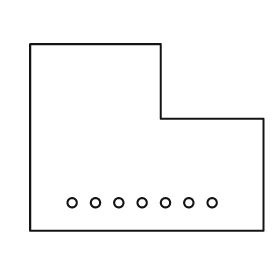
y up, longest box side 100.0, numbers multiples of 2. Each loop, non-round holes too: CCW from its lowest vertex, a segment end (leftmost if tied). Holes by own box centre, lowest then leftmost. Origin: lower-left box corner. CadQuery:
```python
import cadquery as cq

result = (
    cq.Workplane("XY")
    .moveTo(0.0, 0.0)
    .lineTo(100.0, 0.0)
    .lineTo(100.0, 48.0)
    .lineTo(56.0, 48.0)
    .lineTo(56.0, 80.0)
    .lineTo(0.0, 80.0)
    .close()
    .moveTo(18.0, 12.0)
    .circle(2.0)
    .moveTo(28.0, 12.0)
    .circle(2.0)
    .moveTo(38.0, 12.0)
    .circle(2.0)
    .moveTo(48.0, 12.0)
    .circle(2.0)
    .moveTo(58.0, 12.0)
    .circle(2.0)
    .moveTo(68.0, 12.0)
    .circle(2.0)
    .moveTo(78.0, 12.0)
    .circle(2.0)
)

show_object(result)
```